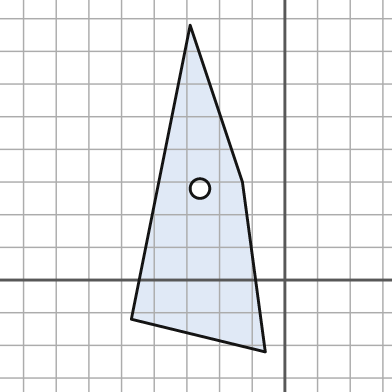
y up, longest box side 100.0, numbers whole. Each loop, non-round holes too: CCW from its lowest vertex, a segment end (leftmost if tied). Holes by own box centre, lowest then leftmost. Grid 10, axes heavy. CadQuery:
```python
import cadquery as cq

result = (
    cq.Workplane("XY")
    .moveTo(-6.0, -22.0)
    .lineTo(-13.0, 30.0)
    .lineTo(-29.0, 78.0)
    .lineTo(-47.0, -12.0)
    .close()
    .moveTo(-26.0, 28.0)
    .circle(3.0)
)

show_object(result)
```